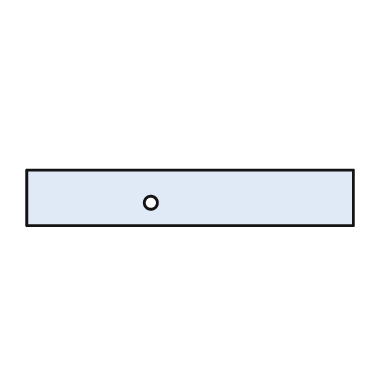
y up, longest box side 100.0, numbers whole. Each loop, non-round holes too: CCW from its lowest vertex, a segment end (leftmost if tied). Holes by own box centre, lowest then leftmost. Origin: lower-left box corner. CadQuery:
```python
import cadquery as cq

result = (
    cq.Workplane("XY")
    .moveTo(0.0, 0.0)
    .lineTo(100.0, 0.0)
    .lineTo(100.0, 17.0)
    .lineTo(0.0, 17.0)
    .close()
    .moveTo(38.0, 7.0)
    .circle(2.0)
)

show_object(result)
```